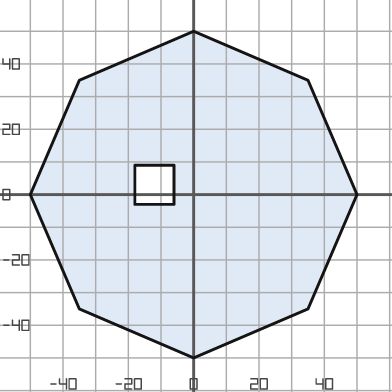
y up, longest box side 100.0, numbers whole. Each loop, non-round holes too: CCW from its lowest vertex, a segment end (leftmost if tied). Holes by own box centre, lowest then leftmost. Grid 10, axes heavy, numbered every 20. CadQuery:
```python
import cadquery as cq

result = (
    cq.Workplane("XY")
    .moveTo(0.0, -50.0)
    .lineTo(35.0, -35.0)
    .lineTo(50.0, 0.0)
    .lineTo(35.0, 35.0)
    .lineTo(0.0, 50.0)
    .lineTo(-35.0, 35.0)
    .lineTo(-50.0, 0.0)
    .lineTo(-35.0, -35.0)
    .close()
    .moveTo(-18.0, -3.0)
    .lineTo(-6.0, -3.0)
    .lineTo(-6.0, 9.0)
    .lineTo(-18.0, 9.0)
    .close()
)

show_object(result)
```